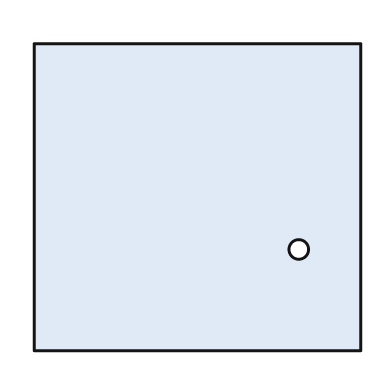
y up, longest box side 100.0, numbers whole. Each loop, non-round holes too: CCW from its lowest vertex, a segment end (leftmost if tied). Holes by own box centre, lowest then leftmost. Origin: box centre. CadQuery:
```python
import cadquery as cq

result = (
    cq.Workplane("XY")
    .moveTo(-50.0, -47.0)
    .lineTo(50.0, -47.0)
    .lineTo(50.0, 47.0)
    .lineTo(-50.0, 47.0)
    .close()
    .moveTo(31.0, -16.0)
    .circle(3.0)
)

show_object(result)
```